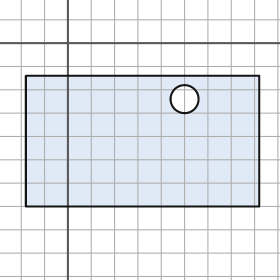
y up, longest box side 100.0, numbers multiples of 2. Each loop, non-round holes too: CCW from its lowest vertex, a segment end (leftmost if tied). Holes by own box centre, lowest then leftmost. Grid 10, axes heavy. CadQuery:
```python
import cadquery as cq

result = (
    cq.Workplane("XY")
    .moveTo(-18.0, -70.0)
    .lineTo(82.0, -70.0)
    .lineTo(82.0, -14.0)
    .lineTo(-18.0, -14.0)
    .close()
    .moveTo(50.0, -24.0)
    .circle(6.0)
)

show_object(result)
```